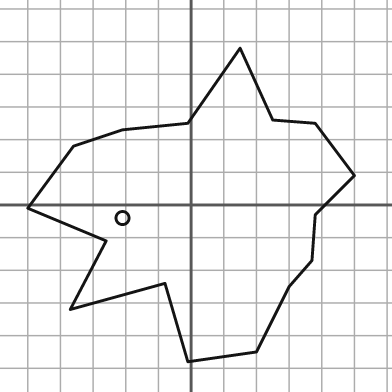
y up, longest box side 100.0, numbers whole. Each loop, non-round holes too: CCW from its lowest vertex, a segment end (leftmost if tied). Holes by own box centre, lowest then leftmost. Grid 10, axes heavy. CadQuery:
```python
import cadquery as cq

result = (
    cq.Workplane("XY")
    .moveTo(-1.0, -48.0)
    .lineTo(20.0, -45.0)
    .lineTo(30.0, -25.0)
    .lineTo(37.0, -17.0)
    .lineTo(38.0, -3.0)
    .lineTo(50.0, 9.0)
    .lineTo(38.0, 25.0)
    .lineTo(25.0, 26.0)
    .lineTo(15.0, 48.0)
    .lineTo(-1.0, 25.0)
    .lineTo(-21.0, 23.0)
    .lineTo(-36.0, 18.0)
    .lineTo(-50.0, -1.0)
    .lineTo(-26.0, -11.0)
    .lineTo(-37.0, -32.0)
    .lineTo(-8.0, -24.0)
    .close()
    .moveTo(-21.0, -4.0)
    .circle(2.0)
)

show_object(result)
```